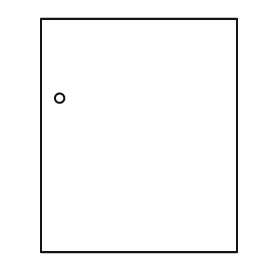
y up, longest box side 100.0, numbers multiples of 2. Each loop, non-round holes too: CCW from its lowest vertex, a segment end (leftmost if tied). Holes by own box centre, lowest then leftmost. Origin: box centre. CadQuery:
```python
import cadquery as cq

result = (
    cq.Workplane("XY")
    .moveTo(-42.0, -50.0)
    .lineTo(42.0, -50.0)
    .lineTo(42.0, 50.0)
    .lineTo(-42.0, 50.0)
    .close()
    .moveTo(-34.0, 16.0)
    .circle(2.0)
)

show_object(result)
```